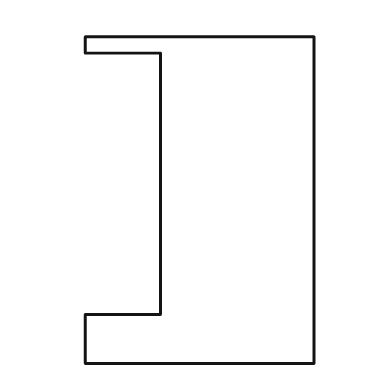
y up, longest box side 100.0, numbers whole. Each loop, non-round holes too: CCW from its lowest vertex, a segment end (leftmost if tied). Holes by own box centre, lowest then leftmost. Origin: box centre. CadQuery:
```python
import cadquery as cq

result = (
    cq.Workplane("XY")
    .moveTo(-35.0, -50.0)
    .lineTo(35.0, -50.0)
    .lineTo(35.0, 50.0)
    .lineTo(-35.0, 50.0)
    .lineTo(-35.0, 45.0)
    .lineTo(-12.0, 45.0)
    .lineTo(-12.0, -35.0)
    .lineTo(-35.0, -35.0)
    .close()
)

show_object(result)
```